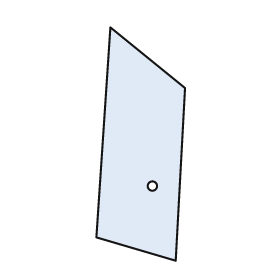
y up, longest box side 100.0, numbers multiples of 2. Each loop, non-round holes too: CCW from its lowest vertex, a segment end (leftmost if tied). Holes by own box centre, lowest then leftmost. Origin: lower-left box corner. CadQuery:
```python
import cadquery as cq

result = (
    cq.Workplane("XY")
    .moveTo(34.0, 0.0)
    .lineTo(38.0, 74.0)
    .lineTo(6.0, 100.0)
    .lineTo(0.0, 10.0)
    .close()
    .moveTo(24.0, 32.0)
    .circle(2.0)
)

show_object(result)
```